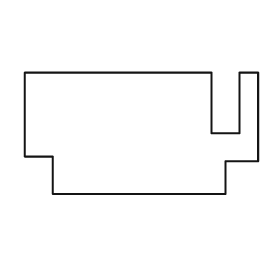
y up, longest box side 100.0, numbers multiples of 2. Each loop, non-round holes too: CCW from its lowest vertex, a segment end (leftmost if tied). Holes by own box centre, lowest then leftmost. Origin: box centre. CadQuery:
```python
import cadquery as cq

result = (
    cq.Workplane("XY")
    .moveTo(-38.0, -26.0)
    .lineTo(36.0, -26.0)
    .lineTo(36.0, -12.0)
    .lineTo(50.0, -12.0)
    .lineTo(50.0, 26.0)
    .lineTo(42.0, 26.0)
    .lineTo(42.0, 0.0)
    .lineTo(30.0, 0.0)
    .lineTo(30.0, 26.0)
    .lineTo(-50.0, 26.0)
    .lineTo(-50.0, -10.0)
    .lineTo(-38.0, -10.0)
    .close()
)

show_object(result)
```